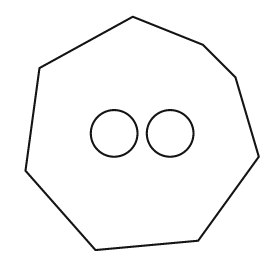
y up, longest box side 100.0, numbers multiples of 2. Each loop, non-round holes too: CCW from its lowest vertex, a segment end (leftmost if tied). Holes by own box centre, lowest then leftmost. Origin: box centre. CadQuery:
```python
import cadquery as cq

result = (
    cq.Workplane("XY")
    .moveTo(-20.0, -50.0)
    .lineTo(24.0, -46.0)
    .lineTo(50.0, -10.0)
    .lineTo(40.0, 24.0)
    .lineTo(26.0, 38.0)
    .lineTo(-4.0, 50.0)
    .lineTo(-44.0, 28.0)
    .lineTo(-50.0, -16.0)
    .close()
    .moveTo(-12.0, 0.0)
    .circle(10.0)
    .moveTo(12.0, 0.0)
    .circle(10.0)
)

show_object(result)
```